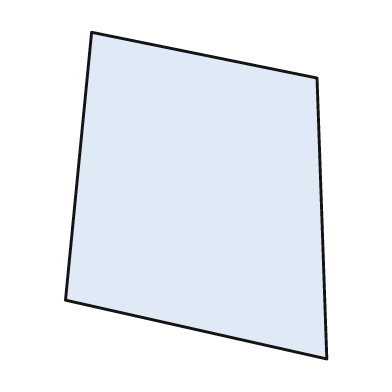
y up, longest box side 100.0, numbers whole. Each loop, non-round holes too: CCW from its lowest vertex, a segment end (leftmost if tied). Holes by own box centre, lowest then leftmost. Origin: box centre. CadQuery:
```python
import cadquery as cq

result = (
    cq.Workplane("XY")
    .moveTo(40.0, -50.0)
    .lineTo(37.0, 36.0)
    .lineTo(-32.0, 50.0)
    .lineTo(-40.0, -32.0)
    .close()
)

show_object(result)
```